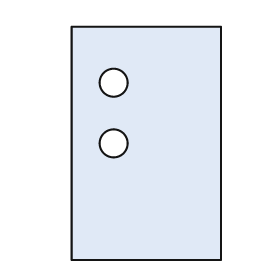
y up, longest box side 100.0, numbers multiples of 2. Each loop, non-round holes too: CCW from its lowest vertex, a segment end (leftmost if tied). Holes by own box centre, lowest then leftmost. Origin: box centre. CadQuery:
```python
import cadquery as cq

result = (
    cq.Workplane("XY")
    .moveTo(-32.0, -50.0)
    .lineTo(32.0, -50.0)
    .lineTo(32.0, 50.0)
    .lineTo(-32.0, 50.0)
    .close()
    .moveTo(-14.0, 0.0)
    .circle(6.0)
    .moveTo(-14.0, 26.0)
    .circle(6.0)
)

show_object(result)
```